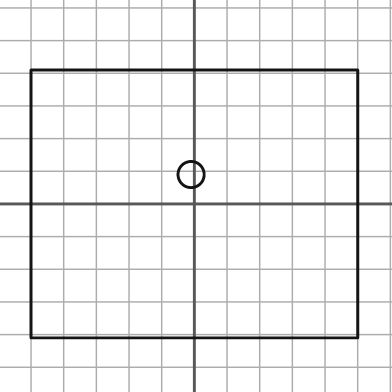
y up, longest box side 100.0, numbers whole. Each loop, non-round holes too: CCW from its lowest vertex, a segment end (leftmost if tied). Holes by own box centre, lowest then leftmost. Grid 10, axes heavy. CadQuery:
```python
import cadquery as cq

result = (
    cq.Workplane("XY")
    .moveTo(-50.0, -41.0)
    .lineTo(50.0, -41.0)
    .lineTo(50.0, 41.0)
    .lineTo(-50.0, 41.0)
    .close()
    .moveTo(-1.0, 9.0)
    .circle(4.0)
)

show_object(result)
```